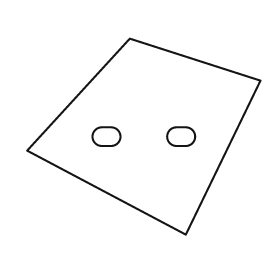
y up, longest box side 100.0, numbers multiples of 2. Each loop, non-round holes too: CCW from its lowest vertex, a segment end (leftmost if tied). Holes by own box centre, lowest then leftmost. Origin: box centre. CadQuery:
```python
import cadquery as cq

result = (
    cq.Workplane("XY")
    .moveTo(18.0, -42.0)
    .lineTo(50.0, 24.0)
    .lineTo(-6.0, 42.0)
    .lineTo(-50.0, -6.0)
    .close()
    .moveTo(-18.0, -4.0)
    .lineTo(-14.0, -4.0)
    .threePointArc((-10.0, 0.0), (-14.0, 4.0))
    .lineTo(-18.0, 4.0)
    .threePointArc((-22.0, 0.0), (-18.0, -4.0))
    .close()
    .moveTo(14.0, -4.0)
    .lineTo(18.0, -4.0)
    .threePointArc((22.0, 0.0), (18.0, 4.0))
    .lineTo(14.0, 4.0)
    .threePointArc((10.0, 0.0), (14.0, -4.0))
    .close()
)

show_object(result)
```